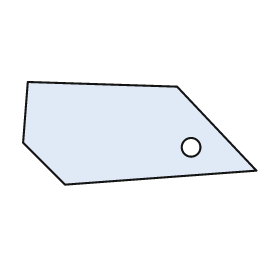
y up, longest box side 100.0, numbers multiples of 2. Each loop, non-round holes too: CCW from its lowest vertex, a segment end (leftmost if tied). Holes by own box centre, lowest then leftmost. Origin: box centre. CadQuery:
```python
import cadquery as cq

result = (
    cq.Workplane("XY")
    .moveTo(-32.0, -22.0)
    .lineTo(50.0, -16.0)
    .lineTo(16.0, 20.0)
    .lineTo(-48.0, 22.0)
    .lineTo(-50.0, -4.0)
    .close()
    .moveTo(22.0, -6.0)
    .circle(4.0)
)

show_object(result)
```